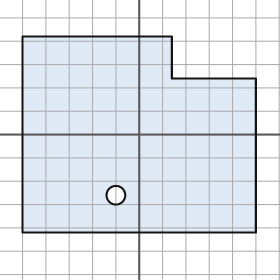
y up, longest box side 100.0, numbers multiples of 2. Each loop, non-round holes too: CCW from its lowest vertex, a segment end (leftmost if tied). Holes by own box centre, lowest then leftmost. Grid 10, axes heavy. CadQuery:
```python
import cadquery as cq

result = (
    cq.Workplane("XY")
    .moveTo(-50.0, -42.0)
    .lineTo(50.0, -42.0)
    .lineTo(50.0, 24.0)
    .lineTo(14.0, 24.0)
    .lineTo(14.0, 42.0)
    .lineTo(-50.0, 42.0)
    .close()
    .moveTo(-10.0, -26.0)
    .circle(4.0)
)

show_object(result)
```